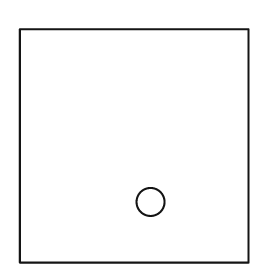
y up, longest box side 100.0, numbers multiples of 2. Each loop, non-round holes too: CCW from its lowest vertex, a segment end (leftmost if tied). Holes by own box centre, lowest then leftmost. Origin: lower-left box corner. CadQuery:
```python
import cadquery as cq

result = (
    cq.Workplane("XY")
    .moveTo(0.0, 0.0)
    .lineTo(98.0, 0.0)
    .lineTo(98.0, 100.0)
    .lineTo(0.0, 100.0)
    .close()
    .moveTo(56.0, 26.0)
    .circle(6.0)
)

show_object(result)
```